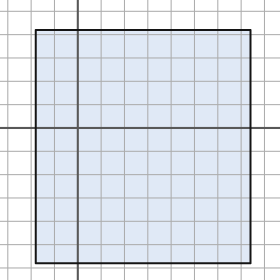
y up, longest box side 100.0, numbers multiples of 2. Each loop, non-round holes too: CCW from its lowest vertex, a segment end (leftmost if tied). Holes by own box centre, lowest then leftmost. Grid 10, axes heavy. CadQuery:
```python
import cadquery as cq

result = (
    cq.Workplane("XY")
    .moveTo(-18.0, -58.0)
    .lineTo(74.0, -58.0)
    .lineTo(74.0, 42.0)
    .lineTo(-18.0, 42.0)
    .close()
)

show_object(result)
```